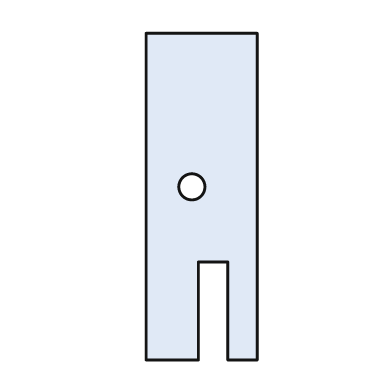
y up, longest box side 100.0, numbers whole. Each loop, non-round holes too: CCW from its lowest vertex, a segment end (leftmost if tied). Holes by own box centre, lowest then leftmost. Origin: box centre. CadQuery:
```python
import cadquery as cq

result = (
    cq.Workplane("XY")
    .moveTo(-17.0, -50.0)
    .lineTo(-1.0, -50.0)
    .lineTo(-1.0, -20.0)
    .lineTo(8.0, -20.0)
    .lineTo(8.0, -50.0)
    .lineTo(17.0, -50.0)
    .lineTo(17.0, 50.0)
    .lineTo(-17.0, 50.0)
    .close()
    .moveTo(-3.0, 3.0)
    .circle(4.0)
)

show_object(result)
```